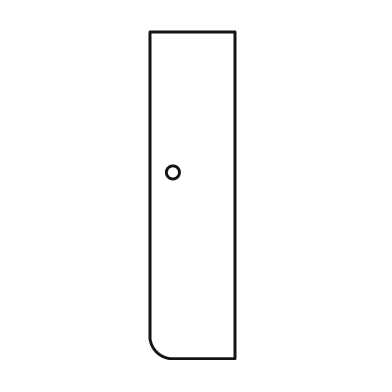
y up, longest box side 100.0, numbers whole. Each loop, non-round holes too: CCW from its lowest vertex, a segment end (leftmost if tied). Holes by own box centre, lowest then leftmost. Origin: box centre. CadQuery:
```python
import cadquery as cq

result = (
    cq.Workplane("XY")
    .moveTo(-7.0, -50.0)
    .lineTo(13.0, -50.0)
    .lineTo(13.0, 50.0)
    .lineTo(-13.0, 50.0)
    .lineTo(-13.0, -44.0)
    .threePointArc((-11.0, -48.0), (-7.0, -50.0))
    .close()
    .moveTo(-6.0, 7.0)
    .circle(2.0)
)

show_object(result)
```